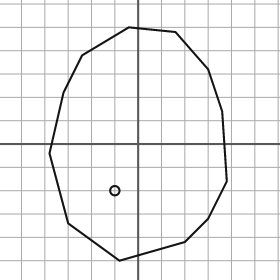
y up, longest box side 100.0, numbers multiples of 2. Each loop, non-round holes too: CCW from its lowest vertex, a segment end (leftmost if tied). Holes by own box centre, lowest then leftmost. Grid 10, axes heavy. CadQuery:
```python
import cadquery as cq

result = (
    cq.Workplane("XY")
    .moveTo(-8.0, -50.0)
    .lineTo(20.0, -42.0)
    .lineTo(30.0, -32.0)
    .lineTo(38.0, -16.0)
    .lineTo(36.0, 14.0)
    .lineTo(30.0, 32.0)
    .lineTo(16.0, 48.0)
    .lineTo(-4.0, 50.0)
    .lineTo(-24.0, 38.0)
    .lineTo(-32.0, 22.0)
    .lineTo(-38.0, -4.0)
    .lineTo(-30.0, -34.0)
    .close()
    .moveTo(-10.0, -20.0)
    .circle(2.0)
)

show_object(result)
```